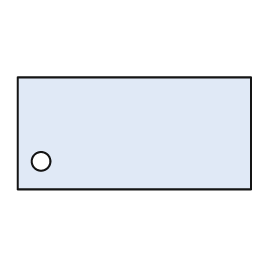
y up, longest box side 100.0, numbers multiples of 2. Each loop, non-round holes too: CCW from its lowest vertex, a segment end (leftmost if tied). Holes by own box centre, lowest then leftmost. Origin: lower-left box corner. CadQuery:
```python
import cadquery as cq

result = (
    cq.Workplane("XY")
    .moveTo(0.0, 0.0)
    .lineTo(100.0, 0.0)
    .lineTo(100.0, 48.0)
    .lineTo(0.0, 48.0)
    .close()
    .moveTo(10.0, 12.0)
    .circle(4.0)
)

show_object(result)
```